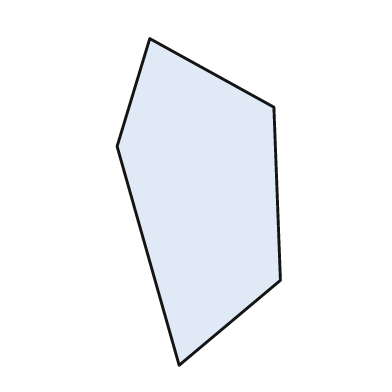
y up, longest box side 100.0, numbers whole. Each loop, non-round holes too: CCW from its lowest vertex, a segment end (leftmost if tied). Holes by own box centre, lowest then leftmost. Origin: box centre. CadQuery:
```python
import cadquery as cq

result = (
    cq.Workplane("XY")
    .moveTo(-6.0, -50.0)
    .lineTo(25.0, -24.0)
    .lineTo(23.0, 29.0)
    .lineTo(-15.0, 50.0)
    .lineTo(-25.0, 17.0)
    .close()
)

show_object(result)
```